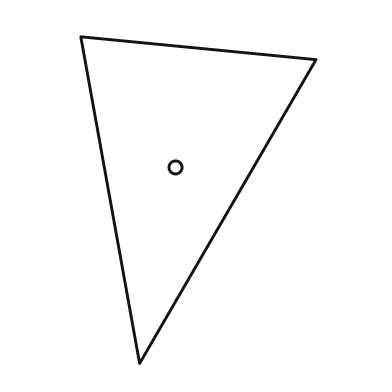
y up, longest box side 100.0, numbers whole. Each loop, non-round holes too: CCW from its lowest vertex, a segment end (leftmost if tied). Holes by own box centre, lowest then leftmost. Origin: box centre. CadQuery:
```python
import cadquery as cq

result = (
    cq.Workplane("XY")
    .moveTo(-18.0, -50.0)
    .lineTo(36.0, 43.0)
    .lineTo(-36.0, 50.0)
    .close()
    .moveTo(-7.0, 10.0)
    .circle(2.0)
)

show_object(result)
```